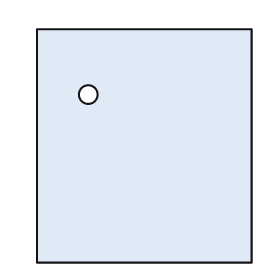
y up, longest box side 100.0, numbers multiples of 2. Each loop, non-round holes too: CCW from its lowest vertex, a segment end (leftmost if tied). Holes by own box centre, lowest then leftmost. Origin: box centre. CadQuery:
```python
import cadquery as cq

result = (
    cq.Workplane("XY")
    .moveTo(-46.0, -50.0)
    .lineTo(46.0, -50.0)
    .lineTo(46.0, 50.0)
    .lineTo(-46.0, 50.0)
    .close()
    .moveTo(-24.0, 22.0)
    .circle(4.0)
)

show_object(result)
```